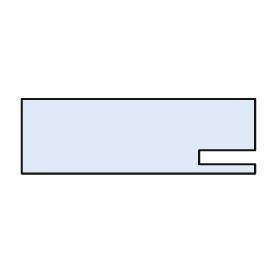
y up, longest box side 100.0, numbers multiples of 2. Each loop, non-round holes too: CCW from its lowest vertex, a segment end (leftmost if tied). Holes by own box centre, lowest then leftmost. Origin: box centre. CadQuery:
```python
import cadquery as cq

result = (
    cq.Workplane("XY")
    .moveTo(-50.0, -16.0)
    .lineTo(50.0, -16.0)
    .lineTo(50.0, -12.0)
    .lineTo(26.0, -12.0)
    .lineTo(26.0, -6.0)
    .lineTo(50.0, -6.0)
    .lineTo(50.0, 16.0)
    .lineTo(-50.0, 16.0)
    .close()
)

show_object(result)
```